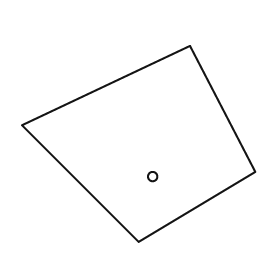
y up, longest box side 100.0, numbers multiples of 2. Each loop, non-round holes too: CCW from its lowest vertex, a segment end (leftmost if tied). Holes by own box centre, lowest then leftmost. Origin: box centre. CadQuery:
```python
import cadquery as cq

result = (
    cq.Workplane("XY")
    .moveTo(0.0, -42.0)
    .lineTo(50.0, -12.0)
    .lineTo(22.0, 42.0)
    .lineTo(-50.0, 8.0)
    .close()
    .moveTo(6.0, -14.0)
    .circle(2.0)
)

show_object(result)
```